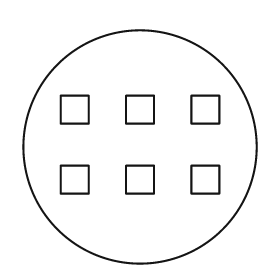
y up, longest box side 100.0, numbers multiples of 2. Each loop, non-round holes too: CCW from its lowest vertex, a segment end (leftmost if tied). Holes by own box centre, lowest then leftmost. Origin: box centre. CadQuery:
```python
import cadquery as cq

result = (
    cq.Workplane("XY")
    .moveTo(0.0, 0.0)
    .circle(50.0)
    .moveTo(-34.0, -20.0)
    .lineTo(-22.0, -20.0)
    .lineTo(-22.0, -8.0)
    .lineTo(-34.0, -8.0)
    .close()
    .moveTo(-6.0, -20.0)
    .lineTo(6.0, -20.0)
    .lineTo(6.0, -8.0)
    .lineTo(-6.0, -8.0)
    .close()
    .moveTo(22.0, -20.0)
    .lineTo(34.0, -20.0)
    .lineTo(34.0, -8.0)
    .lineTo(22.0, -8.0)
    .close()
    .moveTo(-34.0, 10.0)
    .lineTo(-22.0, 10.0)
    .lineTo(-22.0, 22.0)
    .lineTo(-34.0, 22.0)
    .close()
    .moveTo(-6.0, 10.0)
    .lineTo(6.0, 10.0)
    .lineTo(6.0, 22.0)
    .lineTo(-6.0, 22.0)
    .close()
    .moveTo(22.0, 10.0)
    .lineTo(34.0, 10.0)
    .lineTo(34.0, 22.0)
    .lineTo(22.0, 22.0)
    .close()
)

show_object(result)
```